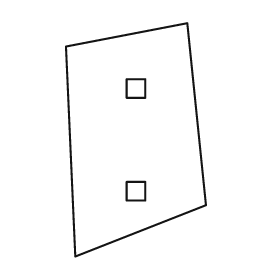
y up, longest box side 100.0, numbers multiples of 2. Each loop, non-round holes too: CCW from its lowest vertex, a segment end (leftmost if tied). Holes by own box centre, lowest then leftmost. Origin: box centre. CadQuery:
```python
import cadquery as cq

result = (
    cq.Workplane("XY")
    .moveTo(-26.0, -50.0)
    .lineTo(30.0, -28.0)
    .lineTo(22.0, 50.0)
    .lineTo(-30.0, 40.0)
    .close()
    .moveTo(-4.0, -26.0)
    .lineTo(4.0, -26.0)
    .lineTo(4.0, -18.0)
    .lineTo(-4.0, -18.0)
    .close()
    .moveTo(-4.0, 18.0)
    .lineTo(4.0, 18.0)
    .lineTo(4.0, 26.0)
    .lineTo(-4.0, 26.0)
    .close()
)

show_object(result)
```